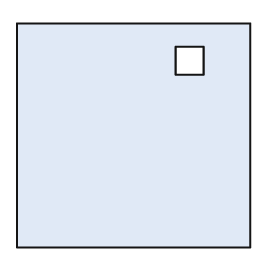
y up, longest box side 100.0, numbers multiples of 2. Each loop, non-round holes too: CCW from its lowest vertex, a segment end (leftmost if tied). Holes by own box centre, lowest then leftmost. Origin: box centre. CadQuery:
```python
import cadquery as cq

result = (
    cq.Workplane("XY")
    .moveTo(-50.0, -48.0)
    .lineTo(50.0, -48.0)
    .lineTo(50.0, 48.0)
    .lineTo(-50.0, 48.0)
    .close()
    .moveTo(18.0, 26.0)
    .lineTo(30.0, 26.0)
    .lineTo(30.0, 38.0)
    .lineTo(18.0, 38.0)
    .close()
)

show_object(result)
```